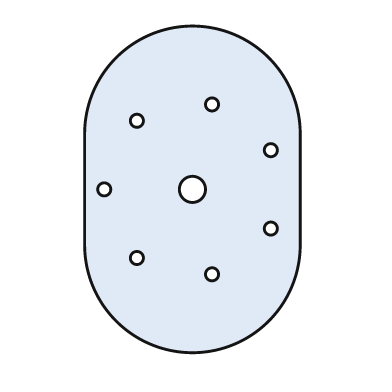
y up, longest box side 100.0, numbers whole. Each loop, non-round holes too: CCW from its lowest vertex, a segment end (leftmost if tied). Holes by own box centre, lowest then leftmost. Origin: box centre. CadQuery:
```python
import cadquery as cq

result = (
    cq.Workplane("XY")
    .moveTo(-33.0, -17.0)
    .threePointArc((0.0, -50.0), (33.0, -17.0))
    .lineTo(33.0, 17.0)
    .threePointArc((0.0, 50.0), (-33.0, 17.0))
    .close()
    .moveTo(6.0, -26.0)
    .circle(2.0)
    .moveTo(-17.0, -21.0)
    .circle(2.0)
    .moveTo(24.0, -12.0)
    .circle(2.0)
    .moveTo(-27.0, 0.0)
    .circle(2.0)
    .moveTo(0.0, 0.0)
    .circle(4.0)
    .moveTo(24.0, 12.0)
    .circle(2.0)
    .moveTo(-17.0, 21.0)
    .circle(2.0)
    .moveTo(6.0, 26.0)
    .circle(2.0)
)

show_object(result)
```